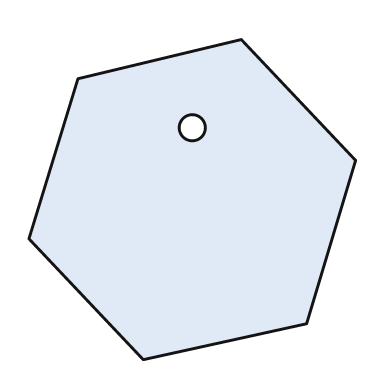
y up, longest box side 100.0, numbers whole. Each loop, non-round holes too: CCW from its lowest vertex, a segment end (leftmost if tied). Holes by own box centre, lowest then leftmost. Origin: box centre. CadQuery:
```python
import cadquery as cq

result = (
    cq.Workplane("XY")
    .moveTo(-15.0, -49.0)
    .lineTo(35.0, -38.0)
    .lineTo(50.0, 12.0)
    .lineTo(15.0, 49.0)
    .lineTo(-35.0, 37.0)
    .lineTo(-50.0, -12.0)
    .close()
    .moveTo(0.0, 22.0)
    .circle(4.0)
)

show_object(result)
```